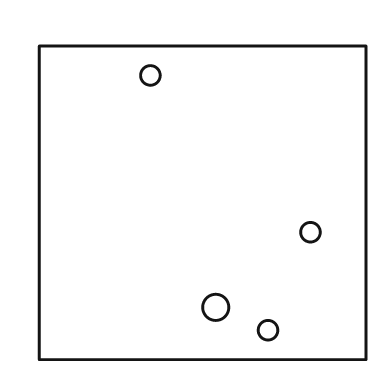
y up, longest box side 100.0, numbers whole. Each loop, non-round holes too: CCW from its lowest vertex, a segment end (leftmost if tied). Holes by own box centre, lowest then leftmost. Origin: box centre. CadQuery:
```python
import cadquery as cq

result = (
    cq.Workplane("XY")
    .moveTo(-50.0, -48.0)
    .lineTo(50.0, -48.0)
    .lineTo(50.0, 48.0)
    .lineTo(-50.0, 48.0)
    .close()
    .moveTo(20.0, -39.0)
    .circle(3.0)
    .moveTo(4.0, -32.0)
    .circle(4.0)
    .moveTo(33.0, -9.0)
    .circle(3.0)
    .moveTo(-16.0, 39.0)
    .circle(3.0)
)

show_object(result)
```